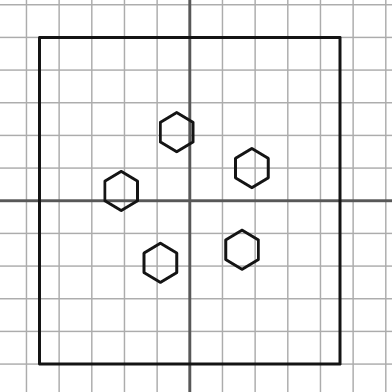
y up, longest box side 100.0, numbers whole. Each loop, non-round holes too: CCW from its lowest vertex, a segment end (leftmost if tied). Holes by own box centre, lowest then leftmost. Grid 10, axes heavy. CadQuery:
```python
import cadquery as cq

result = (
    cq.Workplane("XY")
    .moveTo(-46.0, -50.0)
    .lineTo(46.0, -50.0)
    .lineTo(46.0, 50.0)
    .lineTo(-46.0, 50.0)
    .close()
    .moveTo(-9.0, -25.0)
    .lineTo(-4.0, -22.0)
    .lineTo(-4.0, -16.0)
    .lineTo(-9.0, -13.0)
    .lineTo(-14.0, -16.0)
    .lineTo(-14.0, -22.0)
    .close()
    .moveTo(16.0, -21.0)
    .lineTo(21.0, -18.0)
    .lineTo(21.0, -12.0)
    .lineTo(16.0, -9.0)
    .lineTo(11.0, -12.0)
    .lineTo(11.0, -18.0)
    .close()
    .moveTo(-21.0, -3.0)
    .lineTo(-16.0, 0.0)
    .lineTo(-16.0, 6.0)
    .lineTo(-21.0, 9.0)
    .lineTo(-26.0, 6.0)
    .lineTo(-26.0, 0.0)
    .close()
    .moveTo(19.0, 4.0)
    .lineTo(24.0, 7.0)
    .lineTo(24.0, 13.0)
    .lineTo(19.0, 16.0)
    .lineTo(14.0, 13.0)
    .lineTo(14.0, 7.0)
    .close()
    .moveTo(-4.0, 15.0)
    .lineTo(1.0, 18.0)
    .lineTo(1.0, 24.0)
    .lineTo(-4.0, 27.0)
    .lineTo(-9.0, 24.0)
    .lineTo(-9.0, 18.0)
    .close()
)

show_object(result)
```